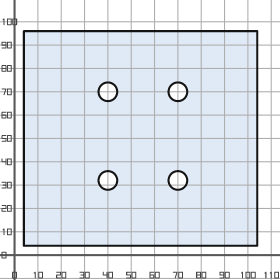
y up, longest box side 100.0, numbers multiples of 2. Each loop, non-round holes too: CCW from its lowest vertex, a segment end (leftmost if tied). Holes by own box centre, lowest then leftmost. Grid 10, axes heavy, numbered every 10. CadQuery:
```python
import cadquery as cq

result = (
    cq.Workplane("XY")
    .moveTo(4.0, 4.0)
    .lineTo(104.0, 4.0)
    .lineTo(104.0, 96.0)
    .lineTo(4.0, 96.0)
    .close()
    .moveTo(40.0, 32.0)
    .circle(4.0)
    .moveTo(70.0, 32.0)
    .circle(4.0)
    .moveTo(40.0, 70.0)
    .circle(4.0)
    .moveTo(70.0, 70.0)
    .circle(4.0)
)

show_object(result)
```